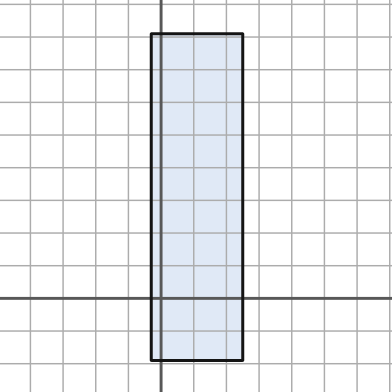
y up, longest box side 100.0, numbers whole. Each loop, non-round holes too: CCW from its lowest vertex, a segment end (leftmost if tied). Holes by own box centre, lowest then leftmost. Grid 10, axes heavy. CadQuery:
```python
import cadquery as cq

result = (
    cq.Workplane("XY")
    .moveTo(-3.0, -19.0)
    .lineTo(25.0, -19.0)
    .lineTo(25.0, 81.0)
    .lineTo(-3.0, 81.0)
    .close()
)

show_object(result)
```